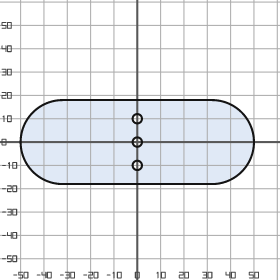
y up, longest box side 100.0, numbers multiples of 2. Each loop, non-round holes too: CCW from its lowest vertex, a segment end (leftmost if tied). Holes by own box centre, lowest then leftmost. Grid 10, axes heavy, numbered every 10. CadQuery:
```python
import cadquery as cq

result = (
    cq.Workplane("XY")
    .moveTo(-32.0, -18.0)
    .lineTo(32.0, -18.0)
    .threePointArc((50.0, 0.0), (32.0, 18.0))
    .lineTo(-32.0, 18.0)
    .threePointArc((-50.0, 0.0), (-32.0, -18.0))
    .close()
    .moveTo(0.0, -10.0)
    .circle(2.0)
    .moveTo(0.0, 0.0)
    .circle(2.0)
    .moveTo(0.0, 10.0)
    .circle(2.0)
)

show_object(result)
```